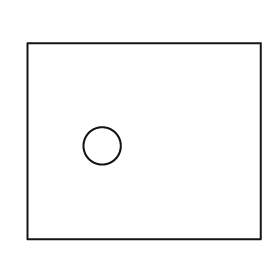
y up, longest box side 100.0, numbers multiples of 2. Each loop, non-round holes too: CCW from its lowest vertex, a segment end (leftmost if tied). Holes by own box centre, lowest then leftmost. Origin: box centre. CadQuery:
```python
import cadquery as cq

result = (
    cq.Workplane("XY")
    .moveTo(-50.0, -42.0)
    .lineTo(50.0, -42.0)
    .lineTo(50.0, 42.0)
    .lineTo(-50.0, 42.0)
    .close()
    .moveTo(-18.0, -2.0)
    .circle(8.0)
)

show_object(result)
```